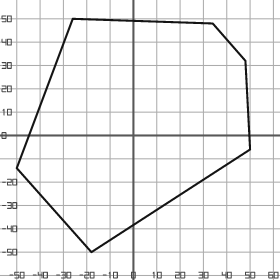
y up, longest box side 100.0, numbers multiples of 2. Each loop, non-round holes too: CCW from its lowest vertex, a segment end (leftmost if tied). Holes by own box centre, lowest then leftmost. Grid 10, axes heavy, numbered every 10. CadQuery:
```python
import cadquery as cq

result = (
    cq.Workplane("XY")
    .moveTo(-18.0, -50.0)
    .lineTo(50.0, -6.0)
    .lineTo(48.0, 32.0)
    .lineTo(34.0, 48.0)
    .lineTo(-26.0, 50.0)
    .lineTo(-50.0, -14.0)
    .close()
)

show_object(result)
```